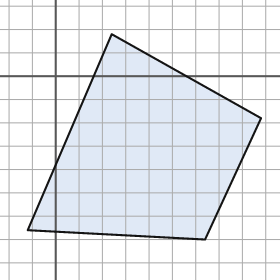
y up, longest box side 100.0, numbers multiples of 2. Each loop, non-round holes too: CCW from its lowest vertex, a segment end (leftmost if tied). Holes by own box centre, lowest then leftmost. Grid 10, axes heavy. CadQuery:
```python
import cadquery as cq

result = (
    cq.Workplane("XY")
    .moveTo(64.0, -70.0)
    .lineTo(88.0, -18.0)
    .lineTo(24.0, 18.0)
    .lineTo(-12.0, -66.0)
    .close()
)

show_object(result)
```